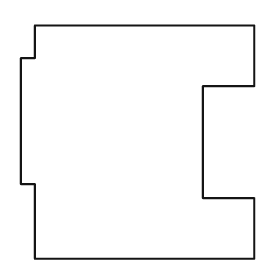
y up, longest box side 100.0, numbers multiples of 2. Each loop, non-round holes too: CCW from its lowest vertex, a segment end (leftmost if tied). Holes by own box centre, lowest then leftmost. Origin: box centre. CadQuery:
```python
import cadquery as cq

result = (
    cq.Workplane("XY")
    .moveTo(-44.0, -50.0)
    .lineTo(50.0, -50.0)
    .lineTo(50.0, -24.0)
    .lineTo(28.0, -24.0)
    .lineTo(28.0, 24.0)
    .lineTo(50.0, 24.0)
    .lineTo(50.0, 50.0)
    .lineTo(-44.0, 50.0)
    .lineTo(-44.0, 36.0)
    .lineTo(-50.0, 36.0)
    .lineTo(-50.0, -18.0)
    .lineTo(-44.0, -18.0)
    .close()
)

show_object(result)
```